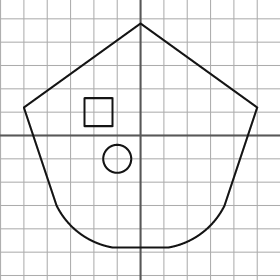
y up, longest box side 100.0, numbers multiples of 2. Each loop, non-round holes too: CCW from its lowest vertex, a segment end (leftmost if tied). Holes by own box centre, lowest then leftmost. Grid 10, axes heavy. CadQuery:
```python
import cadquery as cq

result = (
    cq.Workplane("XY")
    .moveTo(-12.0, -48.0)
    .lineTo(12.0, -48.0)
    .threePointArc((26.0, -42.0), (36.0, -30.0))
    .lineTo(50.0, 12.0)
    .lineTo(0.0, 48.0)
    .lineTo(-50.0, 12.0)
    .lineTo(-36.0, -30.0)
    .threePointArc((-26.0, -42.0), (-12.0, -48.0))
    .close()
    .moveTo(-10.0, -10.0)
    .circle(6.0)
    .moveTo(-24.0, 4.0)
    .lineTo(-12.0, 4.0)
    .lineTo(-12.0, 16.0)
    .lineTo(-24.0, 16.0)
    .close()
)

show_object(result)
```